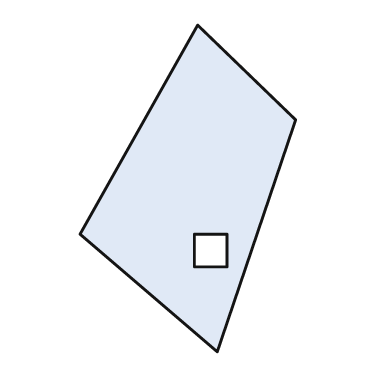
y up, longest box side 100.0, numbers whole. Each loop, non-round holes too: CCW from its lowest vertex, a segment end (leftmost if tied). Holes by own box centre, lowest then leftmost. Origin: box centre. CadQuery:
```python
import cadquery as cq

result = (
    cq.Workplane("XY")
    .moveTo(9.0, -50.0)
    .lineTo(33.0, 21.0)
    .lineTo(3.0, 50.0)
    .lineTo(-33.0, -14.0)
    .close()
    .moveTo(2.0, -24.0)
    .lineTo(12.0, -24.0)
    .lineTo(12.0, -14.0)
    .lineTo(2.0, -14.0)
    .close()
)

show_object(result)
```